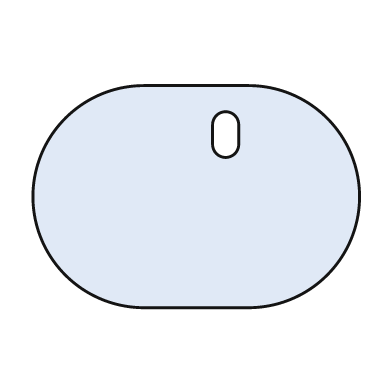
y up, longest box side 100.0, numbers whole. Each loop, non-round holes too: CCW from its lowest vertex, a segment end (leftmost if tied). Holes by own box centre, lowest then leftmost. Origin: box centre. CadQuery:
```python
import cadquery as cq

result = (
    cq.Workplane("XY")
    .moveTo(-16.0, -34.0)
    .lineTo(16.0, -34.0)
    .threePointArc((50.0, 0.0), (16.0, 34.0))
    .lineTo(-16.0, 34.0)
    .threePointArc((-50.0, 0.0), (-16.0, -34.0))
    .close()
    .moveTo(5.0, 16.0)
    .threePointArc((9.0, 12.0), (13.0, 16.0))
    .lineTo(13.0, 22.0)
    .threePointArc((9.0, 26.0), (5.0, 22.0))
    .close()
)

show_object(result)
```